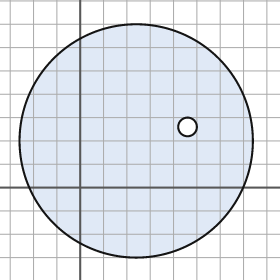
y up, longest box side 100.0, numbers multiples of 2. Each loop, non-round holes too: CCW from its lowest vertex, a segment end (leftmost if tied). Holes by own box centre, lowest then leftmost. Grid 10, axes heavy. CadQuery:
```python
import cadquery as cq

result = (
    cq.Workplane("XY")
    .moveTo(24.0, 20.0)
    .circle(50.0)
    .moveTo(46.0, 26.0)
    .circle(4.0)
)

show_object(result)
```